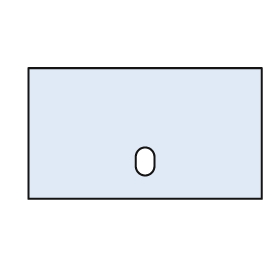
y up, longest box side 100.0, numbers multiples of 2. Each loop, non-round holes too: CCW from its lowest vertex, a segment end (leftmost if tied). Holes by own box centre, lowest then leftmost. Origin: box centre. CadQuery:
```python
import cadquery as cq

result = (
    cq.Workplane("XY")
    .moveTo(-50.0, -28.0)
    .lineTo(50.0, -28.0)
    .lineTo(50.0, 28.0)
    .lineTo(-50.0, 28.0)
    .close()
    .moveTo(-4.0, -14.0)
    .threePointArc((0.0, -18.0), (4.0, -14.0))
    .lineTo(4.0, -10.0)
    .threePointArc((0.0, -6.0), (-4.0, -10.0))
    .close()
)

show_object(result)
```